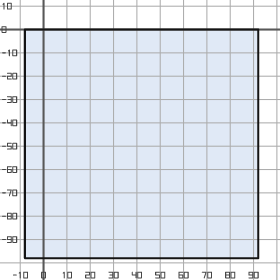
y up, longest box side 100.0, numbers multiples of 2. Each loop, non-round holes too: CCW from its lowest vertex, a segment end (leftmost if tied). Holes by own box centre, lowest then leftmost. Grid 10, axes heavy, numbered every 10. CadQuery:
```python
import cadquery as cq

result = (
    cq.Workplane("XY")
    .moveTo(-8.0, -98.0)
    .lineTo(92.0, -98.0)
    .lineTo(92.0, 0.0)
    .lineTo(-8.0, 0.0)
    .close()
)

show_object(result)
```